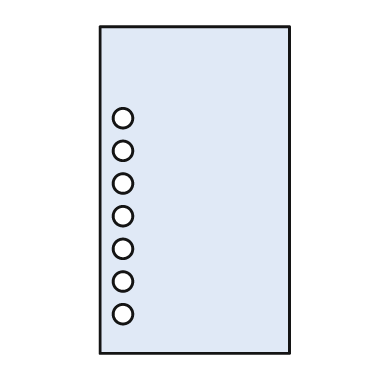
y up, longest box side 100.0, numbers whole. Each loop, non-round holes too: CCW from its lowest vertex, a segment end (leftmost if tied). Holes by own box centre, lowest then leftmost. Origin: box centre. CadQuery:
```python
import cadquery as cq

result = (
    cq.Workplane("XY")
    .moveTo(-29.0, -50.0)
    .lineTo(29.0, -50.0)
    .lineTo(29.0, 50.0)
    .lineTo(-29.0, 50.0)
    .close()
    .moveTo(-22.0, -38.0)
    .circle(3.0)
    .moveTo(-22.0, -28.0)
    .circle(3.0)
    .moveTo(-22.0, -18.0)
    .circle(3.0)
    .moveTo(-22.0, -8.0)
    .circle(3.0)
    .moveTo(-22.0, 2.0)
    .circle(3.0)
    .moveTo(-22.0, 12.0)
    .circle(3.0)
    .moveTo(-22.0, 22.0)
    .circle(3.0)
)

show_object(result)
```